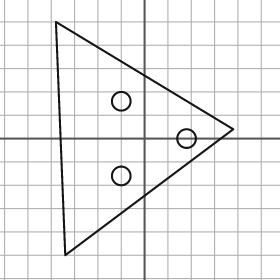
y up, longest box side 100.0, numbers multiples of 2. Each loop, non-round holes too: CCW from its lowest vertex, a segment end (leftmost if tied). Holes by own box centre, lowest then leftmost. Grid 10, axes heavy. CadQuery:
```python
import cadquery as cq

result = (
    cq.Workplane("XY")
    .moveTo(-34.0, -50.0)
    .lineTo(38.0, 4.0)
    .lineTo(-38.0, 50.0)
    .close()
    .moveTo(-10.0, -16.0)
    .circle(4.0)
    .moveTo(18.0, 0.0)
    .circle(4.0)
    .moveTo(-10.0, 16.0)
    .circle(4.0)
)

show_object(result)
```